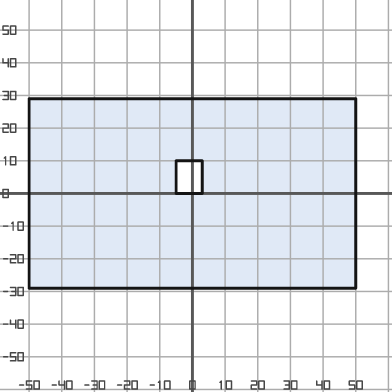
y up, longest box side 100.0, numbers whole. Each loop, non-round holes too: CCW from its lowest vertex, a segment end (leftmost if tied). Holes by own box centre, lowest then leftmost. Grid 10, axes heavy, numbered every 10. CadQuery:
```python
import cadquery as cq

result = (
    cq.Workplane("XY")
    .moveTo(-50.0, -29.0)
    .lineTo(50.0, -29.0)
    .lineTo(50.0, 29.0)
    .lineTo(-50.0, 29.0)
    .close()
    .moveTo(-5.0, 0.0)
    .lineTo(3.0, 0.0)
    .lineTo(3.0, 10.0)
    .lineTo(-5.0, 10.0)
    .close()
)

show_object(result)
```